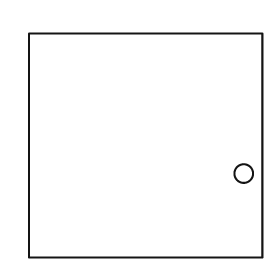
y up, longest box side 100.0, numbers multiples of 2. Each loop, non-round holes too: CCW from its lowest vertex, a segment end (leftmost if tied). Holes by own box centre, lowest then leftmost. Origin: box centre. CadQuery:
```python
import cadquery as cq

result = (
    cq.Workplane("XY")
    .moveTo(-50.0, -48.0)
    .lineTo(50.0, -48.0)
    .lineTo(50.0, 48.0)
    .lineTo(-50.0, 48.0)
    .close()
    .moveTo(42.0, -12.0)
    .circle(4.0)
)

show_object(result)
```